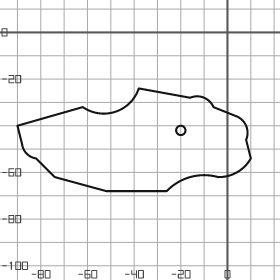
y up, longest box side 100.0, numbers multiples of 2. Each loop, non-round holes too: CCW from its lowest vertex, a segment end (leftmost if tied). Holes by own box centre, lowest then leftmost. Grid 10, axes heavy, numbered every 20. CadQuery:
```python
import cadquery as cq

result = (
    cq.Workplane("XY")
    .moveTo(-52.0, -68.0)
    .lineTo(-26.0, -68.0)
    .threePointArc((-16.0, -62.0), (-4.0, -62.0))
    .threePointArc((4.0, -60.0), (10.0, -54.0))
    .lineTo(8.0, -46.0)
    .threePointArc((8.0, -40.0), (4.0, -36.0))
    .lineTo(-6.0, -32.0)
    .threePointArc((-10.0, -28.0), (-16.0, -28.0))
    .lineTo(-38.0, -24.0)
    .threePointArc((-48.0, -34.0), (-62.0, -32.0))
    .lineTo(-90.0, -40.0)
    .lineTo(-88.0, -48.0)
    .threePointArc((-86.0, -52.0), (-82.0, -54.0))
    .lineTo(-74.0, -62.0)
    .close()
    .moveTo(-20.0, -42.0)
    .circle(2.0)
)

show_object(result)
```